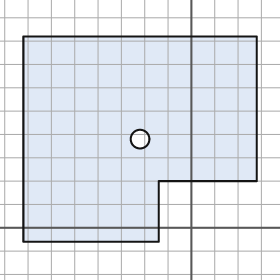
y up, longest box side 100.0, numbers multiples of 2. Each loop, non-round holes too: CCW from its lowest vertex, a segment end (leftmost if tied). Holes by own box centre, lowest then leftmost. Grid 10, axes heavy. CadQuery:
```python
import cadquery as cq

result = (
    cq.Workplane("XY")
    .moveTo(-72.0, -6.0)
    .lineTo(-14.0, -6.0)
    .lineTo(-14.0, 20.0)
    .lineTo(28.0, 20.0)
    .lineTo(28.0, 82.0)
    .lineTo(-72.0, 82.0)
    .close()
    .moveTo(-22.0, 38.0)
    .circle(4.0)
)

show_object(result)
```